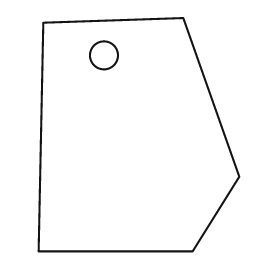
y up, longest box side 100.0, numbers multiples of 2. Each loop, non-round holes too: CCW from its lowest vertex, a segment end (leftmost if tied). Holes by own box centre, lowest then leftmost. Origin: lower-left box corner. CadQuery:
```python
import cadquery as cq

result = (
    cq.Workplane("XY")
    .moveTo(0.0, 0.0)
    .lineTo(66.0, 0.0)
    .lineTo(86.0, 32.0)
    .lineTo(62.0, 100.0)
    .lineTo(2.0, 98.0)
    .close()
    .moveTo(28.0, 84.0)
    .circle(6.0)
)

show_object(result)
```